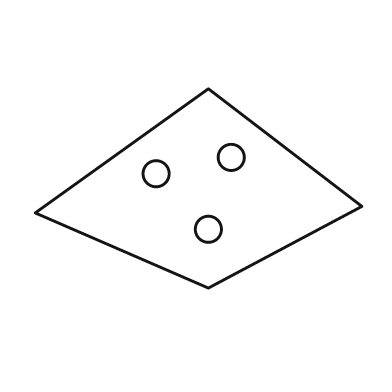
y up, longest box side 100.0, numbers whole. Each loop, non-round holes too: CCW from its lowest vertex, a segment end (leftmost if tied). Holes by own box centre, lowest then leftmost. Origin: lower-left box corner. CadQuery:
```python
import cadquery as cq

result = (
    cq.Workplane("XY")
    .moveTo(53.0, 0.0)
    .lineTo(100.0, 25.0)
    .lineTo(53.0, 61.0)
    .lineTo(0.0, 23.0)
    .close()
    .moveTo(53.0, 18.0)
    .circle(4.0)
    .moveTo(37.0, 35.0)
    .circle(4.0)
    .moveTo(60.0, 40.0)
    .circle(4.0)
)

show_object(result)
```